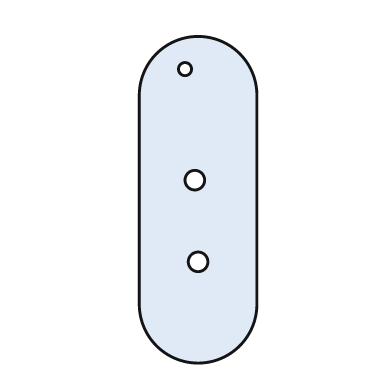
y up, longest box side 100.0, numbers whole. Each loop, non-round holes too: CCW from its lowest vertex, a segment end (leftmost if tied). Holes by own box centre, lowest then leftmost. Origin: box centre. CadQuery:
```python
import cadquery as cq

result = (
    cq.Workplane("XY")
    .moveTo(-18.0, -32.0)
    .threePointArc((0.0, -50.0), (18.0, -32.0))
    .lineTo(18.0, 32.0)
    .threePointArc((0.0, 50.0), (-18.0, 32.0))
    .close()
    .moveTo(0.0, -19.0)
    .circle(3.0)
    .moveTo(-1.0, 6.0)
    .circle(3.0)
    .moveTo(-4.0, 40.0)
    .circle(2.0)
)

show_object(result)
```